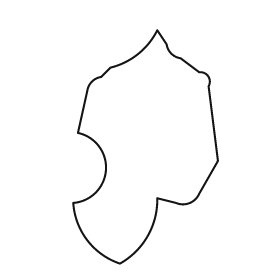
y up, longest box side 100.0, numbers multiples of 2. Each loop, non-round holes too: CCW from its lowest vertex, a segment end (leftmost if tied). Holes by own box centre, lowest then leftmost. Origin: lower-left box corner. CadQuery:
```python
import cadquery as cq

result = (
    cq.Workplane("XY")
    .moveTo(20.0, 0.0)
    .threePointArc((32.0, 12.0), (36.0, 28.0))
    .lineTo(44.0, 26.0)
    .threePointArc((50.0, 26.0), (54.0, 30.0))
    .lineTo(62.0, 44.0)
    .lineTo(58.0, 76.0)
    .threePointArc((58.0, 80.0), (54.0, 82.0))
    .lineTo(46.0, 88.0)
    .threePointArc((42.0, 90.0), (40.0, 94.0))
    .lineTo(36.0, 100.0)
    .threePointArc((28.0, 90.0), (16.0, 84.0))
    .lineTo(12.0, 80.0)
    .threePointArc((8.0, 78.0), (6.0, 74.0))
    .lineTo(2.0, 56.0)
    .threePointArc((14.0, 40.0), (0.0, 26.0))
    .threePointArc((6.0, 10.0), (20.0, 0.0))
    .close()
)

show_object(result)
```